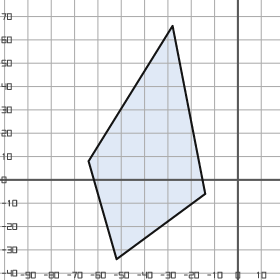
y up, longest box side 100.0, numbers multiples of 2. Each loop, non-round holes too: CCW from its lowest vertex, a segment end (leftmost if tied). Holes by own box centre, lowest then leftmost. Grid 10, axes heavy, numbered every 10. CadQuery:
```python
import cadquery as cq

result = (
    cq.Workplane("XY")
    .moveTo(-52.0, -34.0)
    .lineTo(-14.0, -6.0)
    .lineTo(-28.0, 66.0)
    .lineTo(-64.0, 8.0)
    .close()
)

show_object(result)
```